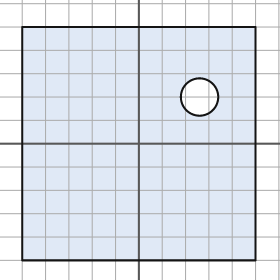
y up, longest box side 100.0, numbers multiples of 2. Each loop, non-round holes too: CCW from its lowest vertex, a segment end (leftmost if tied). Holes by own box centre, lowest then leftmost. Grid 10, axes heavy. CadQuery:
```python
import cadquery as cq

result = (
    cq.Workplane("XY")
    .moveTo(-50.0, -50.0)
    .lineTo(50.0, -50.0)
    .lineTo(50.0, 50.0)
    .lineTo(-50.0, 50.0)
    .close()
    .moveTo(26.0, 20.0)
    .circle(8.0)
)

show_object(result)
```